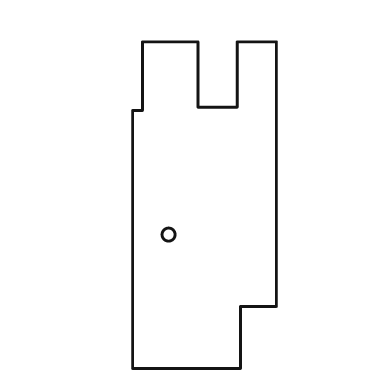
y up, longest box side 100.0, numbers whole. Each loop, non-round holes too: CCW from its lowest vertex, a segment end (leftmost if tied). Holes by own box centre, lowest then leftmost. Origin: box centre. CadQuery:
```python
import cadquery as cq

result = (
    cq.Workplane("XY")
    .moveTo(-22.0, -50.0)
    .lineTo(11.0, -50.0)
    .lineTo(11.0, -31.0)
    .lineTo(22.0, -31.0)
    .lineTo(22.0, 50.0)
    .lineTo(10.0, 50.0)
    .lineTo(10.0, 30.0)
    .lineTo(-2.0, 30.0)
    .lineTo(-2.0, 50.0)
    .lineTo(-19.0, 50.0)
    .lineTo(-19.0, 29.0)
    .lineTo(-22.0, 29.0)
    .close()
    .moveTo(-11.0, -9.0)
    .circle(2.0)
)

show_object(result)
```